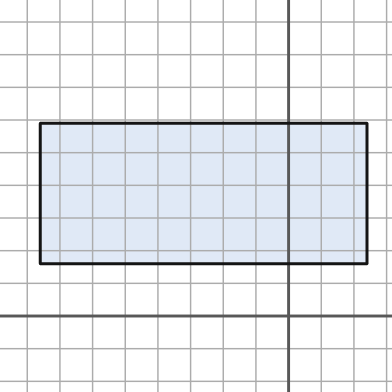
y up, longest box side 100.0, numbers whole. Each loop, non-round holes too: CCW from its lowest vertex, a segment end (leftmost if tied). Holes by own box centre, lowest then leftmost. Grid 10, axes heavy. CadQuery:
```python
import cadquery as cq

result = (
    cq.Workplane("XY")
    .moveTo(-76.0, 16.0)
    .lineTo(24.0, 16.0)
    .lineTo(24.0, 59.0)
    .lineTo(-76.0, 59.0)
    .close()
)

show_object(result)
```